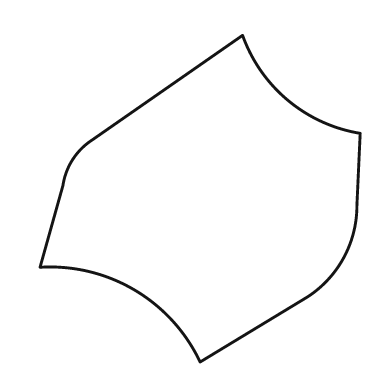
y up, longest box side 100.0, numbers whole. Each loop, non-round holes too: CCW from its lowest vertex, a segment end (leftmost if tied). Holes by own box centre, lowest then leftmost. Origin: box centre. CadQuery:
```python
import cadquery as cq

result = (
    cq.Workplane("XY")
    .moveTo(0.0, -50.0)
    .lineTo(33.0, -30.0)
    .threePointArc((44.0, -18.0), (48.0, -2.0))
    .lineTo(49.0, 20.0)
    .threePointArc((27.0, 30.0), (13.0, 50.0))
    .lineTo(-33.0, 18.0)
    .threePointArc((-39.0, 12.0), (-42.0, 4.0))
    .lineTo(-49.0, -21.0)
    .threePointArc((-20.0, -28.0), (0.0, -50.0))
    .close()
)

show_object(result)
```